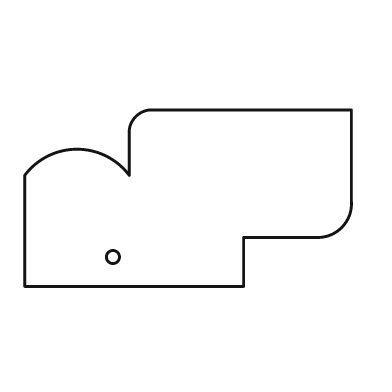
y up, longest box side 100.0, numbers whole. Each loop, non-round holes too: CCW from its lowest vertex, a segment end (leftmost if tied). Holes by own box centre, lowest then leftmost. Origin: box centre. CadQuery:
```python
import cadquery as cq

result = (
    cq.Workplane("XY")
    .moveTo(-50.0, -27.0)
    .lineTo(17.0, -27.0)
    .lineTo(17.0, -12.0)
    .lineTo(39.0, -12.0)
    .threePointArc((47.0, -9.0), (50.0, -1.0))
    .lineTo(50.0, 27.0)
    .lineTo(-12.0, 27.0)
    .threePointArc((-16.0, 25.0), (-18.0, 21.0))
    .lineTo(-18.0, 7.0)
    .threePointArc((-34.0, 15.0), (-50.0, 7.0))
    .close()
    .moveTo(-23.0, -18.0)
    .circle(2.0)
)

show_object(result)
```